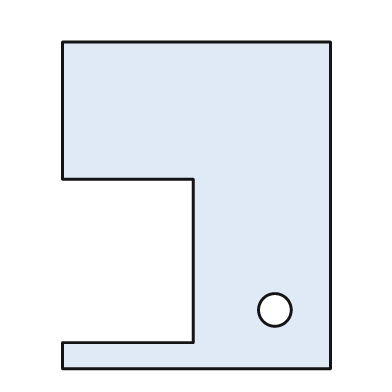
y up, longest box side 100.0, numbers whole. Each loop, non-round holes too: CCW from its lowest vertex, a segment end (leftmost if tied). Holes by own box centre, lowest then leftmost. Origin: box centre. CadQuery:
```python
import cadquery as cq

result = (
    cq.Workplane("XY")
    .moveTo(-41.0, -50.0)
    .lineTo(41.0, -50.0)
    .lineTo(41.0, 50.0)
    .lineTo(-41.0, 50.0)
    .lineTo(-41.0, 8.0)
    .lineTo(-1.0, 8.0)
    .lineTo(-1.0, -42.0)
    .lineTo(-41.0, -42.0)
    .close()
    .moveTo(24.0, -32.0)
    .circle(5.0)
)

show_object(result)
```